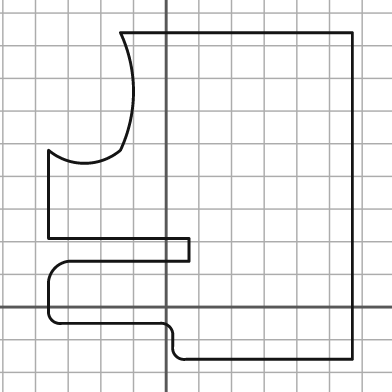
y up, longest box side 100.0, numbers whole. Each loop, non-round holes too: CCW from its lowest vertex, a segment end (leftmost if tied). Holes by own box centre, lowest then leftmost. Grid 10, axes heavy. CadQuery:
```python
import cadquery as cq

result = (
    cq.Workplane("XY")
    .moveTo(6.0, -16.0)
    .lineTo(57.0, -16.0)
    .lineTo(57.0, 84.0)
    .lineTo(-14.0, 84.0)
    .threePointArc((-10.0, 66.0), (-14.0, 48.0))
    .threePointArc((-25.0, 44.0), (-36.0, 48.0))
    .lineTo(-36.0, 21.0)
    .lineTo(7.0, 21.0)
    .lineTo(7.0, 14.0)
    .lineTo(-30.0, 14.0)
    .threePointArc((-34.0, 12.0), (-36.0, 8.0))
    .lineTo(-36.0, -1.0)
    .threePointArc((-35.0, -4.0), (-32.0, -5.0))
    .lineTo(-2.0, -5.0)
    .threePointArc((1.0, -6.0), (2.0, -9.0))
    .lineTo(2.0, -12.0)
    .threePointArc((3.0, -15.0), (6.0, -16.0))
    .close()
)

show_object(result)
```